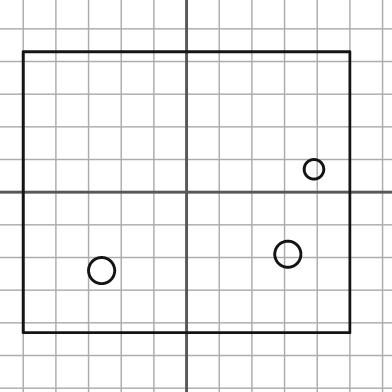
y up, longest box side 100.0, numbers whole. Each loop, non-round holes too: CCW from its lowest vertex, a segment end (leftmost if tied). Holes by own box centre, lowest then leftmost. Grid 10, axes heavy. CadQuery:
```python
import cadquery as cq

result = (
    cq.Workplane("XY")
    .moveTo(-50.0, -43.0)
    .lineTo(50.0, -43.0)
    .lineTo(50.0, 43.0)
    .lineTo(-50.0, 43.0)
    .close()
    .moveTo(-26.0, -24.0)
    .circle(4.0)
    .moveTo(31.0, -19.0)
    .circle(4.0)
    .moveTo(39.0, 7.0)
    .circle(3.0)
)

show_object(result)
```